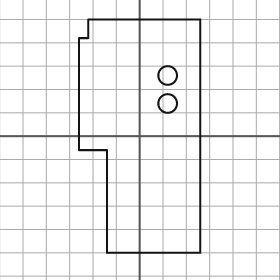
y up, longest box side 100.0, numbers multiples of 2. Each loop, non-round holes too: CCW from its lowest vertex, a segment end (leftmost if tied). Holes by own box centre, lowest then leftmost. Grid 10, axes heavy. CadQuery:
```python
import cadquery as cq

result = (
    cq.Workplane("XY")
    .moveTo(-14.0, -50.0)
    .lineTo(26.0, -50.0)
    .lineTo(26.0, 50.0)
    .lineTo(-22.0, 50.0)
    .lineTo(-22.0, 42.0)
    .lineTo(-26.0, 42.0)
    .lineTo(-26.0, -6.0)
    .lineTo(-14.0, -6.0)
    .close()
    .moveTo(12.0, 14.0)
    .circle(4.0)
    .moveTo(12.0, 26.0)
    .circle(4.0)
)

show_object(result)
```